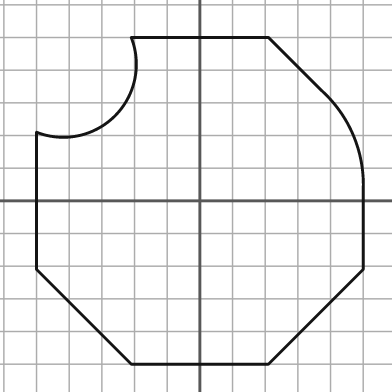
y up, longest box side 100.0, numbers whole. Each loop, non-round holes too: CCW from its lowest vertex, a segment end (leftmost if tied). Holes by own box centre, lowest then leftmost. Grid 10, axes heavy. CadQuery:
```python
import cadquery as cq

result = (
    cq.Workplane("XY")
    .moveTo(-21.0, -50.0)
    .lineTo(21.0, -50.0)
    .lineTo(50.0, -21.0)
    .lineTo(50.0, 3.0)
    .threePointArc((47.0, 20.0), (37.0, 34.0))
    .lineTo(21.0, 50.0)
    .lineTo(-21.0, 50.0)
    .threePointArc((-26.0, 26.0), (-50.0, 21.0))
    .lineTo(-50.0, -21.0)
    .close()
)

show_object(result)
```